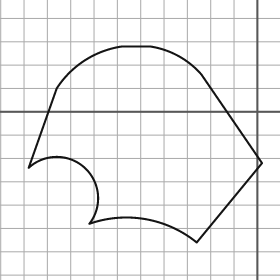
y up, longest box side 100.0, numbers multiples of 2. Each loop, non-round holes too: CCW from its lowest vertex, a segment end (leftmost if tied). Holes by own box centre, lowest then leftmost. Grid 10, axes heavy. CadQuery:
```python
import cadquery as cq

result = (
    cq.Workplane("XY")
    .moveTo(-26.0, -56.0)
    .lineTo(2.0, -22.0)
    .lineTo(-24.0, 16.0)
    .threePointArc((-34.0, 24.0), (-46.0, 28.0))
    .lineTo(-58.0, 28.0)
    .threePointArc((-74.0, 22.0), (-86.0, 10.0))
    .lineTo(-98.0, -24.0)
    .threePointArc((-74.0, -24.0), (-72.0, -48.0))
    .threePointArc((-48.0, -46.0), (-26.0, -56.0))
    .close()
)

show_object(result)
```